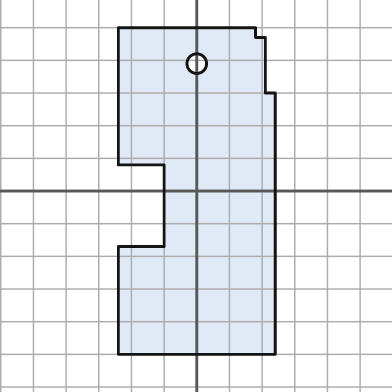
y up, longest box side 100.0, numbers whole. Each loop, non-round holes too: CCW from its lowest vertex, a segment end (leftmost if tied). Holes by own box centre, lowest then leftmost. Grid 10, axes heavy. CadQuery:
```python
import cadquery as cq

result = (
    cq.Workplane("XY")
    .moveTo(-24.0, -50.0)
    .lineTo(24.0, -50.0)
    .lineTo(24.0, 30.0)
    .lineTo(21.0, 30.0)
    .lineTo(21.0, 47.0)
    .lineTo(18.0, 47.0)
    .lineTo(18.0, 50.0)
    .lineTo(-24.0, 50.0)
    .lineTo(-24.0, 8.0)
    .lineTo(-10.0, 8.0)
    .lineTo(-10.0, -17.0)
    .lineTo(-24.0, -17.0)
    .close()
    .moveTo(0.0, 39.0)
    .circle(3.0)
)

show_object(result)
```